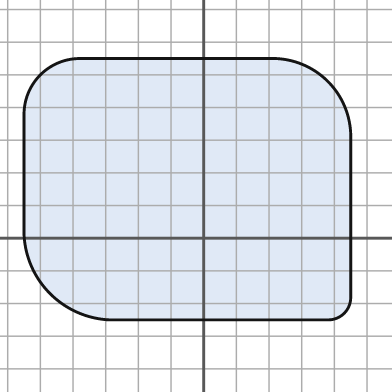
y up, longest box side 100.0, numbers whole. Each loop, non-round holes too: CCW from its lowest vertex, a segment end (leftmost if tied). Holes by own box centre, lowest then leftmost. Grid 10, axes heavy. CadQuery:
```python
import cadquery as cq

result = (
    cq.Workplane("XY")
    .moveTo(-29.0, -25.0)
    .lineTo(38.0, -25.0)
    .threePointArc((43.0, -23.0), (45.0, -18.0))
    .lineTo(45.0, 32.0)
    .threePointArc((38.0, 48.0), (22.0, 55.0))
    .lineTo(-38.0, 55.0)
    .threePointArc((-50.0, 50.0), (-55.0, 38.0))
    .lineTo(-55.0, 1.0)
    .threePointArc((-47.0, -17.0), (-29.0, -25.0))
    .close()
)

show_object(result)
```